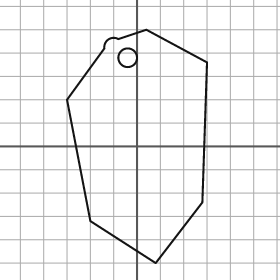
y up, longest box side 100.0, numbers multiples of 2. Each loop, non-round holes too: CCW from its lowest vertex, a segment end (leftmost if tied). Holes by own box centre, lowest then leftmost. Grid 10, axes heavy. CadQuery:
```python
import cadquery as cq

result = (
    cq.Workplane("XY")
    .moveTo(8.0, -50.0)
    .lineTo(28.0, -24.0)
    .lineTo(30.0, 36.0)
    .lineTo(4.0, 50.0)
    .lineTo(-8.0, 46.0)
    .threePointArc((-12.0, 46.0), (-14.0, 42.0))
    .lineTo(-30.0, 20.0)
    .lineTo(-20.0, -32.0)
    .close()
    .moveTo(-4.0, 38.0)
    .circle(4.0)
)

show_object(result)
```